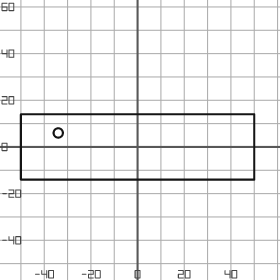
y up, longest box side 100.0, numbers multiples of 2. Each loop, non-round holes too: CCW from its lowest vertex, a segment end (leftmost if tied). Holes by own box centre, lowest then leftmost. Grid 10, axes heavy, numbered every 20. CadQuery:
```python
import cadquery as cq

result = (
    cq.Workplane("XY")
    .moveTo(-50.0, -14.0)
    .lineTo(50.0, -14.0)
    .lineTo(50.0, 14.0)
    .lineTo(-50.0, 14.0)
    .close()
    .moveTo(-34.0, 6.0)
    .circle(2.0)
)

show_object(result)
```